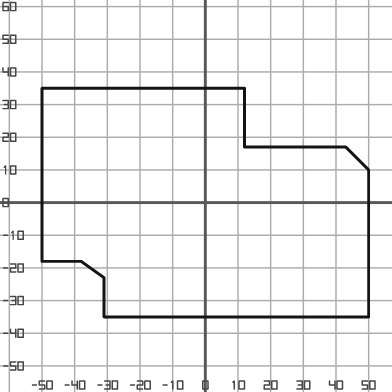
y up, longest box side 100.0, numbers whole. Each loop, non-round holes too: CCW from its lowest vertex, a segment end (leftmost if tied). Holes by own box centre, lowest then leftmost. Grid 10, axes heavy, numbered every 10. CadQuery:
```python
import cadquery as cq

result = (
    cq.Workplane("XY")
    .moveTo(-31.0, -35.0)
    .lineTo(50.0, -35.0)
    .lineTo(50.0, 10.0)
    .lineTo(43.0, 17.0)
    .lineTo(12.0, 17.0)
    .lineTo(12.0, 35.0)
    .lineTo(-50.0, 35.0)
    .lineTo(-50.0, -18.0)
    .lineTo(-38.0, -18.0)
    .lineTo(-31.0, -23.0)
    .close()
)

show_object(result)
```